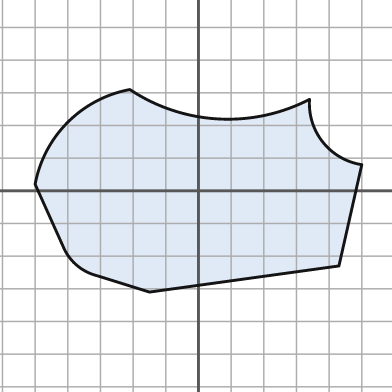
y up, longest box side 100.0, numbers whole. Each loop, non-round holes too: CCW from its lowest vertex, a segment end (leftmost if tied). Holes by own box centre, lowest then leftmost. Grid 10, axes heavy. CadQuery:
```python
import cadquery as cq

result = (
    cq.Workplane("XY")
    .moveTo(-15.0, -31.0)
    .lineTo(43.0, -23.0)
    .lineTo(50.0, 8.0)
    .threePointArc((38.0, 15.0), (34.0, 28.0))
    .threePointArc((6.0, 22.0), (-21.0, 31.0))
    .threePointArc((-40.0, 21.0), (-50.0, 2.0))
    .lineTo(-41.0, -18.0)
    .threePointArc((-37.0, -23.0), (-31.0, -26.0))
    .close()
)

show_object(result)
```